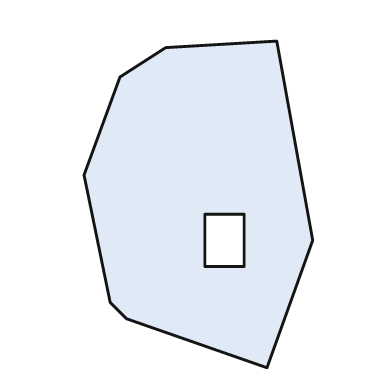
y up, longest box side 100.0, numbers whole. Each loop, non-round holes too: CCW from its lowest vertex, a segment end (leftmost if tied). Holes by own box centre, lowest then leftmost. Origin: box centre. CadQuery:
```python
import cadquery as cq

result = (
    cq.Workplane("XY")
    .moveTo(21.0, -50.0)
    .lineTo(35.0, -11.0)
    .lineTo(24.0, 50.0)
    .lineTo(-10.0, 48.0)
    .lineTo(-24.0, 39.0)
    .lineTo(-35.0, 9.0)
    .lineTo(-27.0, -30.0)
    .lineTo(-22.0, -35.0)
    .close()
    .moveTo(2.0, -19.0)
    .lineTo(14.0, -19.0)
    .lineTo(14.0, -3.0)
    .lineTo(2.0, -3.0)
    .close()
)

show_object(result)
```